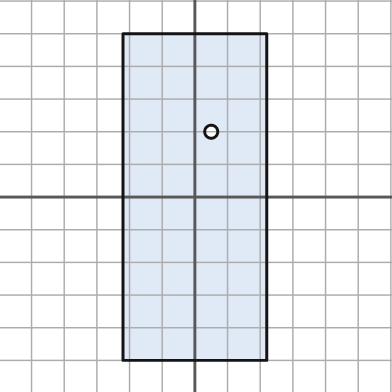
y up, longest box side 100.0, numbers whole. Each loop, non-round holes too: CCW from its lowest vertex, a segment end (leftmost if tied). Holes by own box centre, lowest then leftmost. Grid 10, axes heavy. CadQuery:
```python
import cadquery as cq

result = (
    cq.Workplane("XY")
    .moveTo(-22.0, -50.0)
    .lineTo(22.0, -50.0)
    .lineTo(22.0, 50.0)
    .lineTo(-22.0, 50.0)
    .close()
    .moveTo(5.0, 20.0)
    .circle(2.0)
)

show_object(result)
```